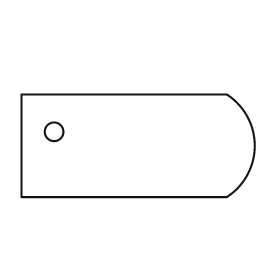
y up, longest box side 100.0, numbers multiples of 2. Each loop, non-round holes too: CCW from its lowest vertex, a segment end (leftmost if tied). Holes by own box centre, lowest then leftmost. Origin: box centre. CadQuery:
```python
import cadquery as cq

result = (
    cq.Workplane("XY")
    .moveTo(-50.0, -22.0)
    .lineTo(38.0, -22.0)
    .threePointArc((50.0, 0.0), (38.0, 22.0))
    .lineTo(-50.0, 22.0)
    .close()
    .moveTo(-36.0, 6.0)
    .circle(4.0)
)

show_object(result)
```